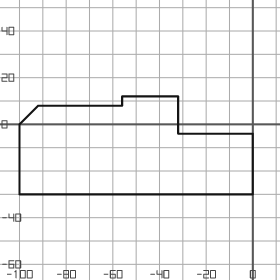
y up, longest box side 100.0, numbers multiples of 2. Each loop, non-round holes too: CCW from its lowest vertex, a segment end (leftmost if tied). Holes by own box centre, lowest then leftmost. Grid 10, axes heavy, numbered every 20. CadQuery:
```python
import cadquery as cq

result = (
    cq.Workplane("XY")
    .moveTo(-100.0, -30.0)
    .lineTo(0.0, -30.0)
    .lineTo(0.0, -4.0)
    .lineTo(-32.0, -4.0)
    .lineTo(-32.0, 12.0)
    .lineTo(-56.0, 12.0)
    .lineTo(-56.0, 8.0)
    .lineTo(-92.0, 8.0)
    .lineTo(-100.0, 0.0)
    .close()
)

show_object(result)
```